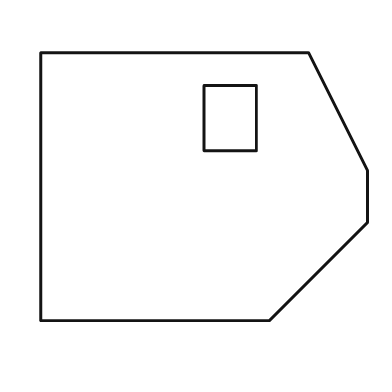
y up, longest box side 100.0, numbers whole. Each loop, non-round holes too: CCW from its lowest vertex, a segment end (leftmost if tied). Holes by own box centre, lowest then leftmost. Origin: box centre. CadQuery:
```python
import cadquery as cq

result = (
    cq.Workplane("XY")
    .moveTo(-50.0, -41.0)
    .lineTo(20.0, -41.0)
    .lineTo(50.0, -11.0)
    .lineTo(50.0, 5.0)
    .lineTo(32.0, 41.0)
    .lineTo(-50.0, 41.0)
    .close()
    .moveTo(0.0, 11.0)
    .lineTo(16.0, 11.0)
    .lineTo(16.0, 31.0)
    .lineTo(0.0, 31.0)
    .close()
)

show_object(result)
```